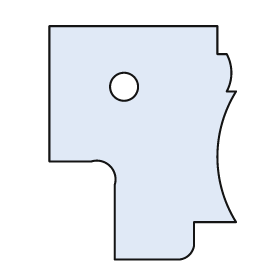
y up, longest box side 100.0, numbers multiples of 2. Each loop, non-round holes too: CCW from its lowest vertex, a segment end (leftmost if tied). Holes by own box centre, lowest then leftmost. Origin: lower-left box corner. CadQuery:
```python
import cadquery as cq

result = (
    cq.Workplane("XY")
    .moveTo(28.0, 0.0)
    .lineTo(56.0, 0.0)
    .threePointArc((60.0, 2.0), (62.0, 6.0))
    .lineTo(62.0, 16.0)
    .lineTo(80.0, 16.0)
    .threePointArc((72.0, 44.0), (80.0, 72.0))
    .lineTo(76.0, 72.0)
    .threePointArc((78.0, 80.0), (76.0, 88.0))
    .lineTo(72.0, 88.0)
    .lineTo(72.0, 100.0)
    .lineTo(0.0, 100.0)
    .lineTo(0.0, 42.0)
    .lineTo(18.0, 42.0)
    .threePointArc((26.0, 40.0), (28.0, 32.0))
    .close()
    .moveTo(32.0, 74.0)
    .circle(6.0)
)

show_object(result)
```